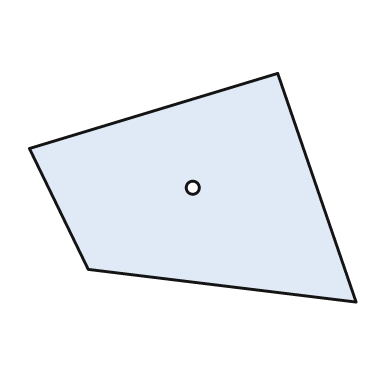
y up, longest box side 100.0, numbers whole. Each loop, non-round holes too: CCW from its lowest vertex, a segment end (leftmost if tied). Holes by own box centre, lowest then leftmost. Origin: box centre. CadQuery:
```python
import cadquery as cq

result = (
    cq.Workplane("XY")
    .moveTo(50.0, -35.0)
    .lineTo(26.0, 35.0)
    .lineTo(-50.0, 12.0)
    .lineTo(-32.0, -25.0)
    .close()
    .moveTo(0.0, 0.0)
    .circle(2.0)
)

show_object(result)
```